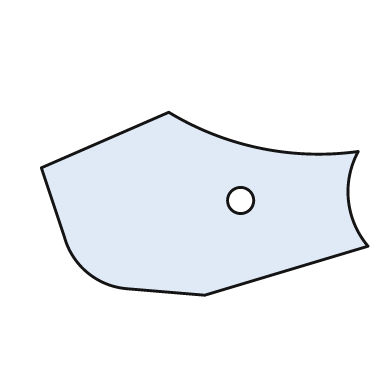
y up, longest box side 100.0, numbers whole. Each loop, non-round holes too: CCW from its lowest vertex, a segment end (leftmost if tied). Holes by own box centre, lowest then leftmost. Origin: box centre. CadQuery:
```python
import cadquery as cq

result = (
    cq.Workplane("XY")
    .moveTo(0.0, -28.0)
    .lineTo(50.0, -13.0)
    .threePointArc((44.0, 1.0), (47.0, 16.0))
    .threePointArc((17.0, 17.0), (-11.0, 28.0))
    .lineTo(-50.0, 11.0)
    .lineTo(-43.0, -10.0)
    .threePointArc((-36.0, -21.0), (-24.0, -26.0))
    .close()
    .moveTo(11.0, 1.0)
    .circle(4.0)
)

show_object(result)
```